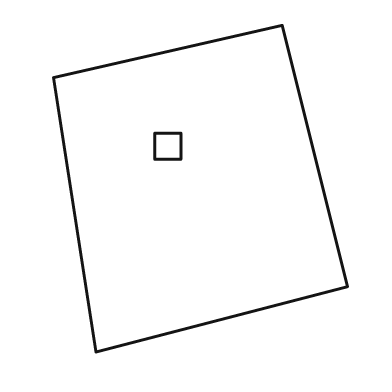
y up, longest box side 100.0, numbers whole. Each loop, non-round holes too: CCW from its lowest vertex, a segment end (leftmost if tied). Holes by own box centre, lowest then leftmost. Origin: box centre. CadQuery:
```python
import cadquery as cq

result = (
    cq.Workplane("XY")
    .moveTo(-32.0, -50.0)
    .lineTo(45.0, -30.0)
    .lineTo(25.0, 50.0)
    .lineTo(-45.0, 34.0)
    .close()
    .moveTo(-14.0, 9.0)
    .lineTo(-6.0, 9.0)
    .lineTo(-6.0, 17.0)
    .lineTo(-14.0, 17.0)
    .close()
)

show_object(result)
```